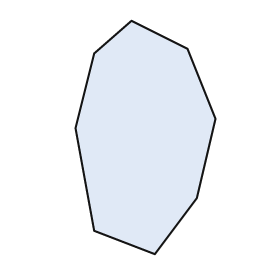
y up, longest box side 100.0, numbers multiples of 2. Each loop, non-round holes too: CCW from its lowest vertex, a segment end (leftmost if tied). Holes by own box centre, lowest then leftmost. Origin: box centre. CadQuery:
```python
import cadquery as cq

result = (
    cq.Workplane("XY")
    .moveTo(4.0, -50.0)
    .lineTo(22.0, -26.0)
    .lineTo(30.0, 8.0)
    .lineTo(18.0, 38.0)
    .lineTo(-6.0, 50.0)
    .lineTo(-22.0, 36.0)
    .lineTo(-30.0, 4.0)
    .lineTo(-22.0, -40.0)
    .close()
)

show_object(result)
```